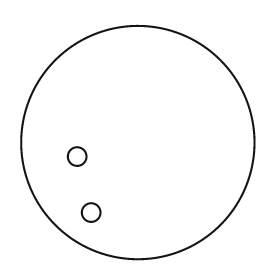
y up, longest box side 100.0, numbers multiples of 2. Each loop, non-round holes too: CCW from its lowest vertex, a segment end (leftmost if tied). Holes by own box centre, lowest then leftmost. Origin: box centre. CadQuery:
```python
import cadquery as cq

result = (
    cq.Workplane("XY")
    .moveTo(0.0, 0.0)
    .circle(50.0)
    .moveTo(-20.0, -30.0)
    .circle(4.0)
    .moveTo(-26.0, -6.0)
    .circle(4.0)
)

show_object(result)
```